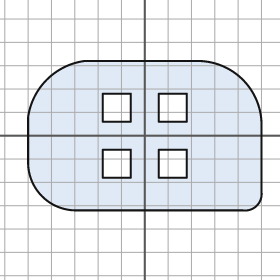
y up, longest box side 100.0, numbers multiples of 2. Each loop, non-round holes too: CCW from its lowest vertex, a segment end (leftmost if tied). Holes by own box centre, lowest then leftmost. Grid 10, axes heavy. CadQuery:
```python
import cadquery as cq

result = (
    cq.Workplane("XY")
    .moveTo(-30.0, -32.0)
    .lineTo(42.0, -32.0)
    .threePointArc((48.0, -30.0), (50.0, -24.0))
    .lineTo(50.0, 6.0)
    .threePointArc((42.0, 24.0), (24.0, 32.0))
    .lineTo(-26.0, 32.0)
    .threePointArc((-42.0, 24.0), (-50.0, 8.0))
    .lineTo(-50.0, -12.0)
    .threePointArc((-44.0, -26.0), (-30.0, -32.0))
    .close()
    .moveTo(-18.0, -18.0)
    .lineTo(-6.0, -18.0)
    .lineTo(-6.0, -6.0)
    .lineTo(-18.0, -6.0)
    .close()
    .moveTo(6.0, -18.0)
    .lineTo(18.0, -18.0)
    .lineTo(18.0, -6.0)
    .lineTo(6.0, -6.0)
    .close()
    .moveTo(-18.0, 6.0)
    .lineTo(-6.0, 6.0)
    .lineTo(-6.0, 18.0)
    .lineTo(-18.0, 18.0)
    .close()
    .moveTo(6.0, 6.0)
    .lineTo(18.0, 6.0)
    .lineTo(18.0, 18.0)
    .lineTo(6.0, 18.0)
    .close()
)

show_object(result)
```